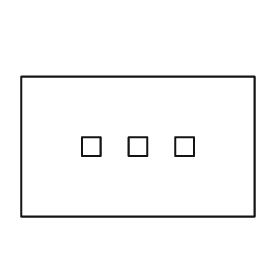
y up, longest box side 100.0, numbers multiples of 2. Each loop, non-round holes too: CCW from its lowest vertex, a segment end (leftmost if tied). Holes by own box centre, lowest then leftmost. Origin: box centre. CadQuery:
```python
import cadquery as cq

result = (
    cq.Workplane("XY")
    .moveTo(-50.0, -30.0)
    .lineTo(50.0, -30.0)
    .lineTo(50.0, 30.0)
    .lineTo(-50.0, 30.0)
    .close()
    .moveTo(-24.0, -4.0)
    .lineTo(-16.0, -4.0)
    .lineTo(-16.0, 4.0)
    .lineTo(-24.0, 4.0)
    .close()
    .moveTo(-4.0, -4.0)
    .lineTo(4.0, -4.0)
    .lineTo(4.0, 4.0)
    .lineTo(-4.0, 4.0)
    .close()
    .moveTo(16.0, -4.0)
    .lineTo(24.0, -4.0)
    .lineTo(24.0, 4.0)
    .lineTo(16.0, 4.0)
    .close()
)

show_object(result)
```